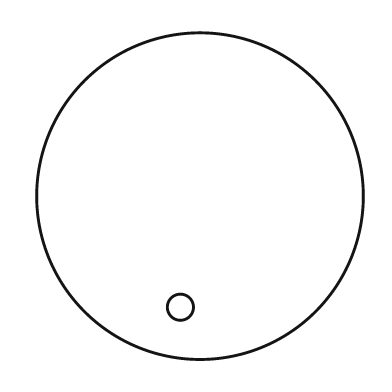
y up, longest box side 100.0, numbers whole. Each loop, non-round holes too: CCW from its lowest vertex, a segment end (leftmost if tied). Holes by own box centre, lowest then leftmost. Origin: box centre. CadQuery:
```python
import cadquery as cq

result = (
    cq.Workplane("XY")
    .moveTo(0.0, 0.0)
    .circle(50.0)
    .moveTo(-6.0, -34.0)
    .circle(4.0)
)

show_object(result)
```